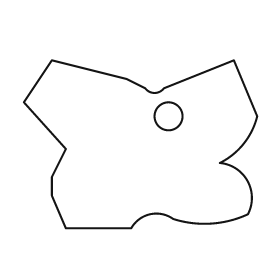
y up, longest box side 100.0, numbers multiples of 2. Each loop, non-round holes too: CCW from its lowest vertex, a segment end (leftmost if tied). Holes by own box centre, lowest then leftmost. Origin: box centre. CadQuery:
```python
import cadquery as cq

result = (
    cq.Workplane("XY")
    .moveTo(-32.0, -36.0)
    .lineTo(-4.0, -36.0)
    .threePointArc((4.0, -30.0), (14.0, -32.0))
    .threePointArc((30.0, -34.0), (46.0, -30.0))
    .threePointArc((46.0, -16.0), (34.0, -8.0))
    .threePointArc((44.0, 0.0), (50.0, 12.0))
    .lineTo(40.0, 36.0)
    .lineTo(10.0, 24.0)
    .threePointArc((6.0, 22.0), (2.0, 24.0))
    .lineTo(-6.0, 28.0)
    .lineTo(-38.0, 36.0)
    .lineTo(-50.0, 18.0)
    .lineTo(-32.0, -2.0)
    .lineTo(-38.0, -14.0)
    .lineTo(-38.0, -22.0)
    .close()
    .moveTo(12.0, 12.0)
    .circle(6.0)
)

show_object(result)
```